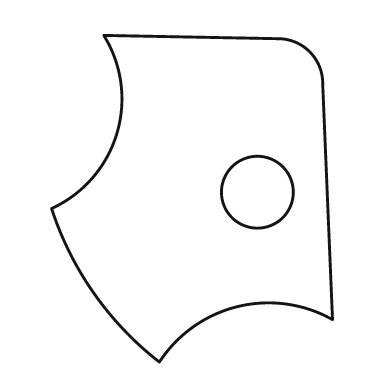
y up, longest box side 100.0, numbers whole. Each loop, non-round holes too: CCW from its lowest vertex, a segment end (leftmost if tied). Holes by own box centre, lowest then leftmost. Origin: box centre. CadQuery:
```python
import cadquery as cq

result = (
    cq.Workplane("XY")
    .moveTo(-10.0, -50.0)
    .threePointArc((14.0, -33.0), (43.0, -37.0))
    .lineTo(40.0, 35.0)
    .threePointArc((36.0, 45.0), (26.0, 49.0))
    .lineTo(-27.0, 50.0)
    .threePointArc((-23.0, 20.0), (-43.0, -3.0))
    .threePointArc((-30.0, -29.0), (-10.0, -50.0))
    .close()
    .moveTo(20.0, 2.0)
    .circle(11.0)
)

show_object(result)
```